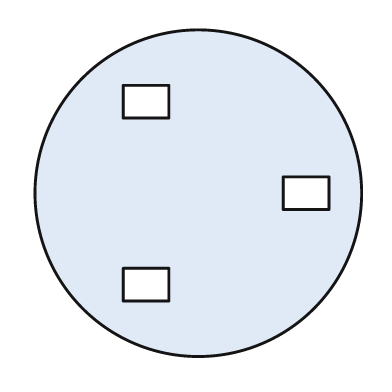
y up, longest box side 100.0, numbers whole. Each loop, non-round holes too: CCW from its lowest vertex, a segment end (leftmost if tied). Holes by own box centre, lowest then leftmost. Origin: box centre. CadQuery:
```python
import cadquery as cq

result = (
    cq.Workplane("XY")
    .moveTo(0.0, 0.0)
    .circle(50.0)
    .moveTo(-23.0, -33.0)
    .lineTo(-9.0, -33.0)
    .lineTo(-9.0, -23.0)
    .lineTo(-23.0, -23.0)
    .close()
    .moveTo(26.0, -5.0)
    .lineTo(40.0, -5.0)
    .lineTo(40.0, 5.0)
    .lineTo(26.0, 5.0)
    .close()
    .moveTo(-23.0, 23.0)
    .lineTo(-9.0, 23.0)
    .lineTo(-9.0, 33.0)
    .lineTo(-23.0, 33.0)
    .close()
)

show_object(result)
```